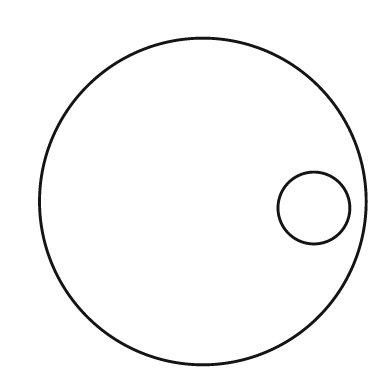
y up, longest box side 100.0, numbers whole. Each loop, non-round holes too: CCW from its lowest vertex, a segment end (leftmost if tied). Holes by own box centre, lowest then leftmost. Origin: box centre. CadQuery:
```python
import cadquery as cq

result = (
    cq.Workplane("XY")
    .moveTo(0.0, 0.0)
    .circle(50.0)
    .moveTo(34.0, -2.0)
    .circle(11.0)
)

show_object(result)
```